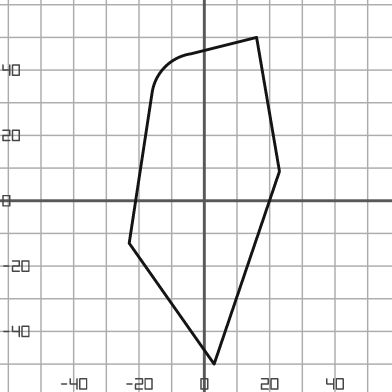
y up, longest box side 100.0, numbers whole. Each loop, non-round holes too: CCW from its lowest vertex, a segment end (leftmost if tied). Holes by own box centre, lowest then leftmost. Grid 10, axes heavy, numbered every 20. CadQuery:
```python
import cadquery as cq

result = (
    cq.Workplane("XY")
    .moveTo(3.0, -50.0)
    .lineTo(23.0, 9.0)
    .lineTo(16.0, 50.0)
    .lineTo(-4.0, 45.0)
    .threePointArc((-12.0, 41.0), (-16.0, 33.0))
    .lineTo(-23.0, -13.0)
    .close()
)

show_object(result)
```